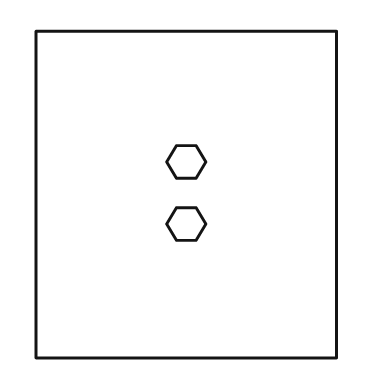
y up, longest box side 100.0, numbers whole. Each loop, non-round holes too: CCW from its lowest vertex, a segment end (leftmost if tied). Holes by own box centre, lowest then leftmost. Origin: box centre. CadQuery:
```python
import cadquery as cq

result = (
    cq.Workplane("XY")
    .moveTo(-46.0, -50.0)
    .lineTo(46.0, -50.0)
    .lineTo(46.0, 50.0)
    .lineTo(-46.0, 50.0)
    .close()
    .moveTo(-3.0, -14.0)
    .lineTo(3.0, -14.0)
    .lineTo(6.0, -9.0)
    .lineTo(3.0, -4.0)
    .lineTo(-3.0, -4.0)
    .lineTo(-6.0, -9.0)
    .close()
    .moveTo(-3.0, 5.0)
    .lineTo(3.0, 5.0)
    .lineTo(6.0, 10.0)
    .lineTo(3.0, 15.0)
    .lineTo(-3.0, 15.0)
    .lineTo(-6.0, 10.0)
    .close()
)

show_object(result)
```